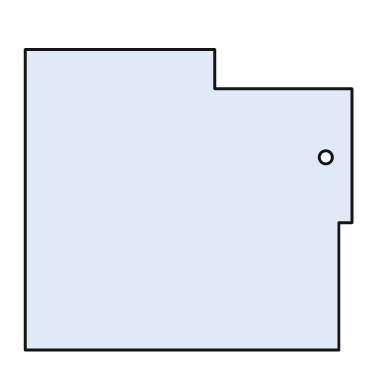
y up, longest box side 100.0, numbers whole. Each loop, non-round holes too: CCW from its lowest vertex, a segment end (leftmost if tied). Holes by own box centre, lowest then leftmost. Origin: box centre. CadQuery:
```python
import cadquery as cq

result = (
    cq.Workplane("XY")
    .moveTo(-50.0, -46.0)
    .lineTo(46.0, -46.0)
    .lineTo(46.0, -7.0)
    .lineTo(50.0, -7.0)
    .lineTo(50.0, 34.0)
    .lineTo(8.0, 34.0)
    .lineTo(8.0, 46.0)
    .lineTo(-50.0, 46.0)
    .close()
    .moveTo(42.0, 13.0)
    .circle(2.0)
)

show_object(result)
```